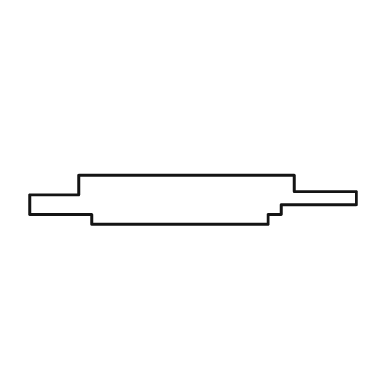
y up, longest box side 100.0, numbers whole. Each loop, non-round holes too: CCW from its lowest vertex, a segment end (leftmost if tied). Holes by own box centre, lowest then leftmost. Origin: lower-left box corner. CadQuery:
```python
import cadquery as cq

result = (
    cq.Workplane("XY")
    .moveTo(19.0, 0.0)
    .lineTo(73.0, 0.0)
    .lineTo(73.0, 3.0)
    .lineTo(77.0, 3.0)
    .lineTo(77.0, 6.0)
    .lineTo(100.0, 6.0)
    .lineTo(100.0, 10.0)
    .lineTo(81.0, 10.0)
    .lineTo(81.0, 15.0)
    .lineTo(15.0, 15.0)
    .lineTo(15.0, 9.0)
    .lineTo(0.0, 9.0)
    .lineTo(0.0, 3.0)
    .lineTo(19.0, 3.0)
    .close()
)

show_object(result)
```